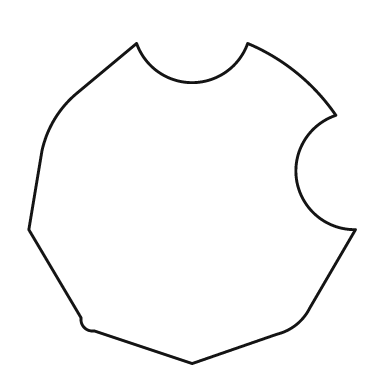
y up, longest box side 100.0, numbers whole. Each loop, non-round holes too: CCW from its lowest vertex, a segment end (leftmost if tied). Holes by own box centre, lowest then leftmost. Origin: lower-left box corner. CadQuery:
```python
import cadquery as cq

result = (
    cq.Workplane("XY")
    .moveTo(50.0, 0.0)
    .lineTo(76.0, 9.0)
    .threePointArc((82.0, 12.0), (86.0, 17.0))
    .lineTo(100.0, 41.0)
    .threePointArc((82.0, 56.0), (94.0, 76.0))
    .threePointArc((82.0, 89.0), (67.0, 98.0))
    .threePointArc((50.0, 86.0), (33.0, 98.0))
    .lineTo(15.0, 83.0)
    .threePointArc((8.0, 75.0), (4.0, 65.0))
    .lineTo(0.0, 41.0)
    .lineTo(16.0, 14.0)
    .threePointArc((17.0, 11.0), (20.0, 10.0))
    .close()
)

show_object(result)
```